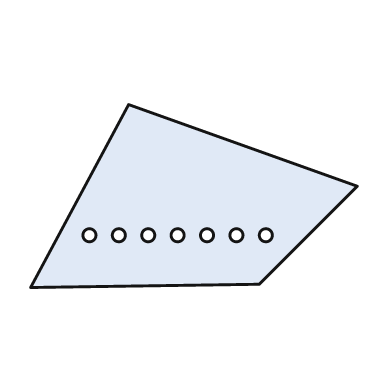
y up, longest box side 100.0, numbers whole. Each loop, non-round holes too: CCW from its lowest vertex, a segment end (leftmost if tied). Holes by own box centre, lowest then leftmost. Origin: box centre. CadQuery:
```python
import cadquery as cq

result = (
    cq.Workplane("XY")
    .moveTo(-50.0, -28.0)
    .lineTo(20.0, -27.0)
    .lineTo(50.0, 3.0)
    .lineTo(-20.0, 28.0)
    .close()
    .moveTo(-32.0, -12.0)
    .circle(2.0)
    .moveTo(-23.0, -12.0)
    .circle(2.0)
    .moveTo(-14.0, -12.0)
    .circle(2.0)
    .moveTo(-5.0, -12.0)
    .circle(2.0)
    .moveTo(4.0, -12.0)
    .circle(2.0)
    .moveTo(13.0, -12.0)
    .circle(2.0)
    .moveTo(22.0, -12.0)
    .circle(2.0)
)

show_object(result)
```